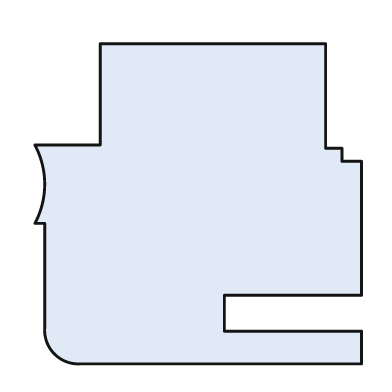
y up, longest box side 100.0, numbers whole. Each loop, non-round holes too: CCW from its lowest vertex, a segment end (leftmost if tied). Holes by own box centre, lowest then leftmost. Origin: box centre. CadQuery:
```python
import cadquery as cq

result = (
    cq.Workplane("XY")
    .moveTo(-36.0, -49.0)
    .lineTo(50.0, -49.0)
    .lineTo(50.0, -39.0)
    .lineTo(8.0, -39.0)
    .lineTo(8.0, -28.0)
    .lineTo(50.0, -28.0)
    .lineTo(50.0, 13.0)
    .lineTo(44.0, 13.0)
    .lineTo(44.0, 17.0)
    .lineTo(39.0, 17.0)
    .lineTo(39.0, 49.0)
    .lineTo(-30.0, 49.0)
    .lineTo(-30.0, 18.0)
    .lineTo(-50.0, 18.0)
    .threePointArc((-47.0, 6.0), (-50.0, -6.0))
    .lineTo(-47.0, -6.0)
    .lineTo(-47.0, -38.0)
    .threePointArc((-44.0, -46.0), (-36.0, -49.0))
    .close()
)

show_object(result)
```